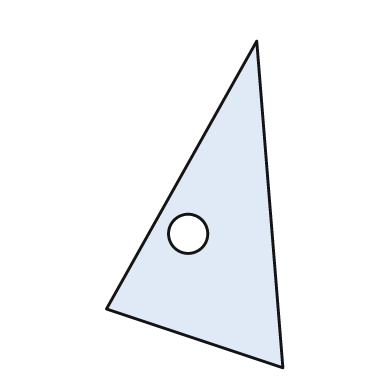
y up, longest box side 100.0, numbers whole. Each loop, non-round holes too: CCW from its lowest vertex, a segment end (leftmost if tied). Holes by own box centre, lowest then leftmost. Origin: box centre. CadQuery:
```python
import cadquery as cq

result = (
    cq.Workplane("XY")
    .moveTo(27.0, -50.0)
    .lineTo(19.0, 50.0)
    .lineTo(-27.0, -32.0)
    .close()
    .moveTo(-2.0, -9.0)
    .circle(6.0)
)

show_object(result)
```